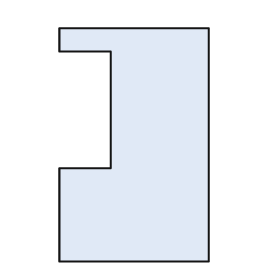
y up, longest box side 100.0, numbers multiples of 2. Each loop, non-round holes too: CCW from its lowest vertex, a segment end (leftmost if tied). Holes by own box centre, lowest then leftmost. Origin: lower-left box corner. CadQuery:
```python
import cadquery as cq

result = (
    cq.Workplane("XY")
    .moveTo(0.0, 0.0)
    .lineTo(64.0, 0.0)
    .lineTo(64.0, 100.0)
    .lineTo(0.0, 100.0)
    .lineTo(0.0, 90.0)
    .lineTo(22.0, 90.0)
    .lineTo(22.0, 40.0)
    .lineTo(0.0, 40.0)
    .close()
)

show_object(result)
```